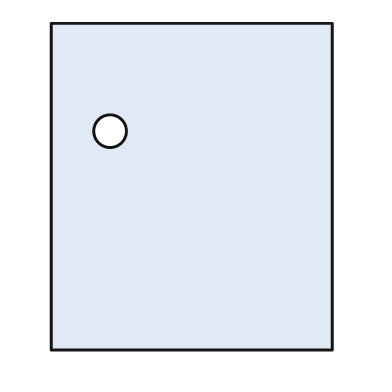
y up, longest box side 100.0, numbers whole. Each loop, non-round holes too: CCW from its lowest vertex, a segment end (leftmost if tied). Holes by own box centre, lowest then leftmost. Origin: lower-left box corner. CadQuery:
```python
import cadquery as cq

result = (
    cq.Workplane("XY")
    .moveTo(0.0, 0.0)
    .lineTo(86.0, 0.0)
    .lineTo(86.0, 100.0)
    .lineTo(0.0, 100.0)
    .close()
    .moveTo(18.0, 67.0)
    .circle(5.0)
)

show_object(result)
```